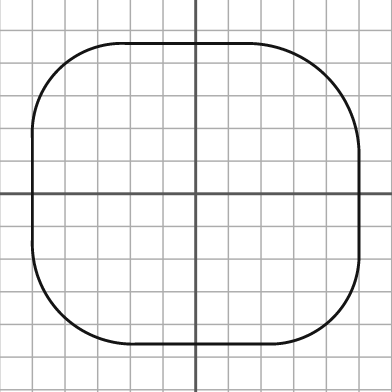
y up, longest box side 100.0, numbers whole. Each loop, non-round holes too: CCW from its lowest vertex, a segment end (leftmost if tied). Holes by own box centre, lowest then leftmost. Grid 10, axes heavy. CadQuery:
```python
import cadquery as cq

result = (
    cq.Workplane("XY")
    .moveTo(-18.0, -46.0)
    .lineTo(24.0, -46.0)
    .threePointArc((42.0, -38.0), (50.0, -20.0))
    .lineTo(50.0, 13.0)
    .threePointArc((40.0, 36.0), (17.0, 46.0))
    .lineTo(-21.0, 46.0)
    .threePointArc((-42.0, 38.0), (-50.0, 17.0))
    .lineTo(-50.0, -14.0)
    .threePointArc((-41.0, -37.0), (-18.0, -46.0))
    .close()
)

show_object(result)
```